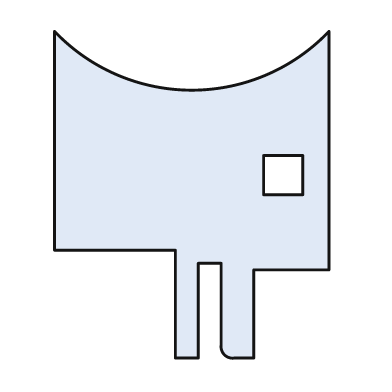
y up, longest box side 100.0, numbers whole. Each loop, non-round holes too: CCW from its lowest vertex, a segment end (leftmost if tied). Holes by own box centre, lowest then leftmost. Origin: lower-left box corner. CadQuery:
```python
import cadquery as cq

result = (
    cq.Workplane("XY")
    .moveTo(37.0, 0.0)
    .lineTo(44.0, 0.0)
    .lineTo(44.0, 29.0)
    .lineTo(51.0, 29.0)
    .lineTo(51.0, 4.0)
    .threePointArc((52.0, 1.0), (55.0, 0.0))
    .lineTo(61.0, 0.0)
    .lineTo(61.0, 27.0)
    .lineTo(84.0, 27.0)
    .lineTo(84.0, 100.0)
    .threePointArc((42.0, 82.0), (0.0, 100.0))
    .lineTo(0.0, 33.0)
    .lineTo(37.0, 33.0)
    .close()
    .moveTo(64.0, 50.0)
    .lineTo(76.0, 50.0)
    .lineTo(76.0, 62.0)
    .lineTo(64.0, 62.0)
    .close()
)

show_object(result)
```